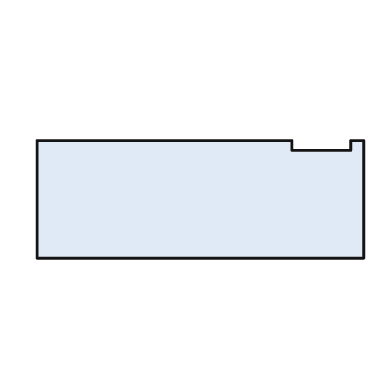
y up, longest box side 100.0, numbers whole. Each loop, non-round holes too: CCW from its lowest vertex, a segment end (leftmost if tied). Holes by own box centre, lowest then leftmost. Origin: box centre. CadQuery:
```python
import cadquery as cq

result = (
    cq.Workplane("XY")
    .moveTo(-50.0, -18.0)
    .lineTo(50.0, -18.0)
    .lineTo(50.0, 18.0)
    .lineTo(46.0, 18.0)
    .lineTo(46.0, 15.0)
    .lineTo(28.0, 15.0)
    .lineTo(28.0, 18.0)
    .lineTo(-50.0, 18.0)
    .close()
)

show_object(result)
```